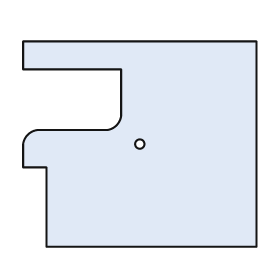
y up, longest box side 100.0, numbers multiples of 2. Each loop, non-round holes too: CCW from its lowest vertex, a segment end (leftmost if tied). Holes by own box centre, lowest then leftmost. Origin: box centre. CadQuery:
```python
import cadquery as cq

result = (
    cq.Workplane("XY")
    .moveTo(-40.0, -44.0)
    .lineTo(50.0, -44.0)
    .lineTo(50.0, 44.0)
    .lineTo(-50.0, 44.0)
    .lineTo(-50.0, 32.0)
    .lineTo(-8.0, 32.0)
    .lineTo(-8.0, 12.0)
    .threePointArc((-10.0, 8.0), (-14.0, 6.0))
    .lineTo(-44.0, 6.0)
    .threePointArc((-48.0, 4.0), (-50.0, 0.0))
    .lineTo(-50.0, -10.0)
    .lineTo(-40.0, -10.0)
    .close()
    .moveTo(0.0, 0.0)
    .circle(2.0)
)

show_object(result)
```